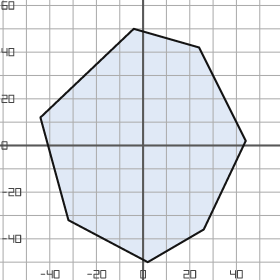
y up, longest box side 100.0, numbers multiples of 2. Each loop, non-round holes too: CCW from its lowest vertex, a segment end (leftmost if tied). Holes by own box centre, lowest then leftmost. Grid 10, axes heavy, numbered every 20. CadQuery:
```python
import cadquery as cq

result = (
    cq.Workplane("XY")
    .moveTo(2.0, -50.0)
    .lineTo(26.0, -36.0)
    .lineTo(44.0, 2.0)
    .lineTo(24.0, 42.0)
    .lineTo(-4.0, 50.0)
    .lineTo(-44.0, 12.0)
    .lineTo(-32.0, -32.0)
    .close()
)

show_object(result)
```